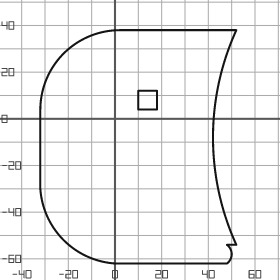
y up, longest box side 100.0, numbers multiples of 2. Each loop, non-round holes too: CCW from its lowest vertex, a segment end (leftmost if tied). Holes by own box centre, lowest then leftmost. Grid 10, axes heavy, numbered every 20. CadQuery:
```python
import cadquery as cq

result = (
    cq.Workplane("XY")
    .moveTo(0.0, -62.0)
    .lineTo(48.0, -62.0)
    .threePointArc((50.0, -58.0), (48.0, -54.0))
    .lineTo(52.0, -54.0)
    .threePointArc((42.0, -8.0), (52.0, 38.0))
    .lineTo(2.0, 38.0)
    .threePointArc((-22.0, 28.0), (-32.0, 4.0))
    .lineTo(-32.0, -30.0)
    .threePointArc((-22.0, -52.0), (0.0, -62.0))
    .close()
    .moveTo(10.0, 4.0)
    .lineTo(18.0, 4.0)
    .lineTo(18.0, 12.0)
    .lineTo(10.0, 12.0)
    .close()
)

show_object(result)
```